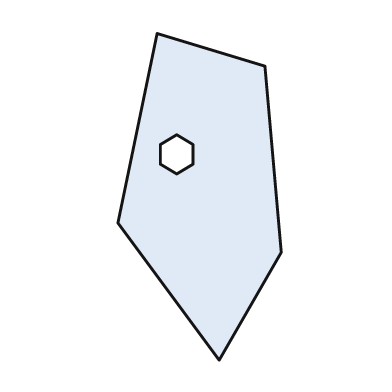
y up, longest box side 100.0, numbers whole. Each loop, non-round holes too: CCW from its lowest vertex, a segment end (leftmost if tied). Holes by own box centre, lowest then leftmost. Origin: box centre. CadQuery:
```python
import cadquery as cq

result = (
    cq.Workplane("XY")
    .moveTo(6.0, -50.0)
    .lineTo(25.0, -17.0)
    .lineTo(20.0, 40.0)
    .lineTo(-13.0, 50.0)
    .lineTo(-25.0, -8.0)
    .close()
    .moveTo(-7.0, 7.0)
    .lineTo(-2.0, 10.0)
    .lineTo(-2.0, 16.0)
    .lineTo(-7.0, 19.0)
    .lineTo(-12.0, 16.0)
    .lineTo(-12.0, 10.0)
    .close()
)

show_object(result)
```